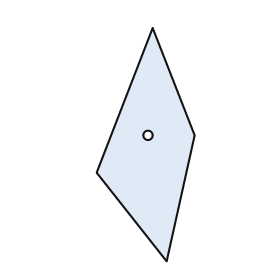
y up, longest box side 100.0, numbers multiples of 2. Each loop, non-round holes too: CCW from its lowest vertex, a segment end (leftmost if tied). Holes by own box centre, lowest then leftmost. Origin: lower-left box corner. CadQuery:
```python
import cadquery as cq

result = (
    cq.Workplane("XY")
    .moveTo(30.0, 0.0)
    .lineTo(42.0, 54.0)
    .lineTo(24.0, 100.0)
    .lineTo(0.0, 38.0)
    .close()
    .moveTo(22.0, 54.0)
    .circle(2.0)
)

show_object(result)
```